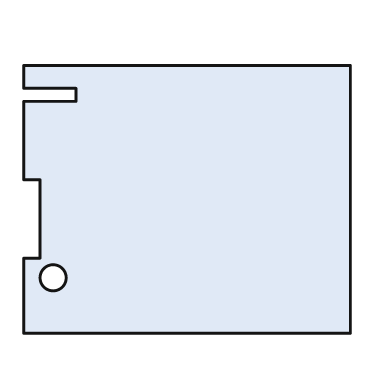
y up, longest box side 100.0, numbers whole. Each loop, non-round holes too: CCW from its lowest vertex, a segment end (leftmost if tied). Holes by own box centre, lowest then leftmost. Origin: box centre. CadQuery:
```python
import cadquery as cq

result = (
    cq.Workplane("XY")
    .moveTo(-50.0, -41.0)
    .lineTo(50.0, -41.0)
    .lineTo(50.0, 41.0)
    .lineTo(-50.0, 41.0)
    .lineTo(-50.0, 34.0)
    .lineTo(-34.0, 34.0)
    .lineTo(-34.0, 30.0)
    .lineTo(-50.0, 30.0)
    .lineTo(-50.0, 6.0)
    .lineTo(-45.0, 6.0)
    .lineTo(-45.0, -18.0)
    .lineTo(-50.0, -18.0)
    .close()
    .moveTo(-41.0, -24.0)
    .circle(4.0)
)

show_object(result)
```